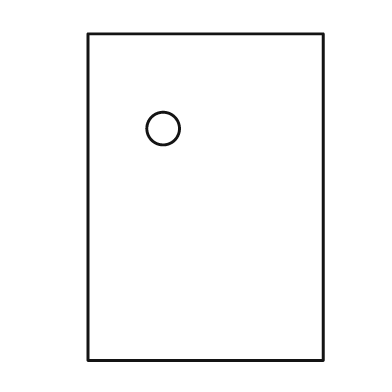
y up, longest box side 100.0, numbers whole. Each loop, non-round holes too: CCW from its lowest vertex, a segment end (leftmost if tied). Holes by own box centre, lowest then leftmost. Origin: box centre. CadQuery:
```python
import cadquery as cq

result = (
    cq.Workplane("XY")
    .moveTo(-36.0, -50.0)
    .lineTo(36.0, -50.0)
    .lineTo(36.0, 50.0)
    .lineTo(-36.0, 50.0)
    .close()
    .moveTo(-13.0, 21.0)
    .circle(5.0)
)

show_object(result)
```